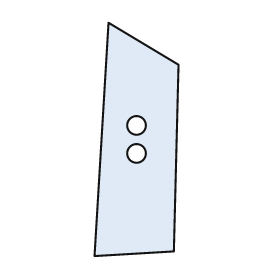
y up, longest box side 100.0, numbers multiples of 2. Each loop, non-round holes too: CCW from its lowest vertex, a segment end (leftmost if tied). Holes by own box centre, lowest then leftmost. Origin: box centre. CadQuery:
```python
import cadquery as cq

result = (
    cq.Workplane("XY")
    .moveTo(-18.0, -50.0)
    .lineTo(16.0, -48.0)
    .lineTo(18.0, 32.0)
    .lineTo(-12.0, 50.0)
    .close()
    .moveTo(0.0, -6.0)
    .circle(4.0)
    .moveTo(0.0, 6.0)
    .circle(4.0)
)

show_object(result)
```